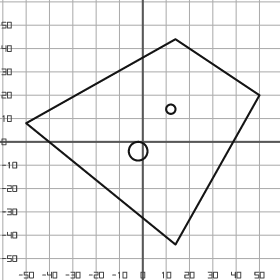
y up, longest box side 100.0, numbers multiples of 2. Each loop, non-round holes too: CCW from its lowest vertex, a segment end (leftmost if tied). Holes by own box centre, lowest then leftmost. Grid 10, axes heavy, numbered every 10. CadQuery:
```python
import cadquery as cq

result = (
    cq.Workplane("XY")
    .moveTo(14.0, -44.0)
    .lineTo(50.0, 20.0)
    .lineTo(14.0, 44.0)
    .lineTo(-50.0, 8.0)
    .close()
    .moveTo(-2.0, -4.0)
    .circle(4.0)
    .moveTo(12.0, 14.0)
    .circle(2.0)
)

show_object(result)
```